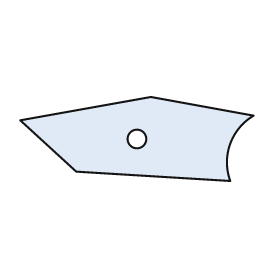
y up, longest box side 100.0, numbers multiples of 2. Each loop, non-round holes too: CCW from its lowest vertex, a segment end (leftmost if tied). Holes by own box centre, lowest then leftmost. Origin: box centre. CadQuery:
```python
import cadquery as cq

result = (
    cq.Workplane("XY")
    .moveTo(40.0, -18.0)
    .threePointArc((40.0, -2.0), (50.0, 10.0))
    .lineTo(6.0, 18.0)
    .lineTo(-50.0, 8.0)
    .lineTo(-26.0, -14.0)
    .close()
    .moveTo(0.0, 0.0)
    .circle(4.0)
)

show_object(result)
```